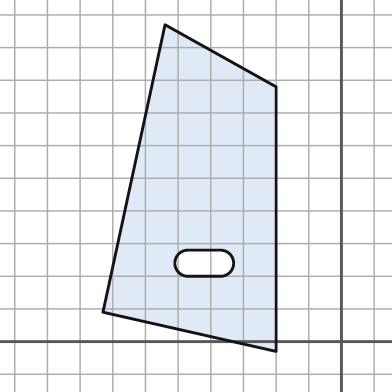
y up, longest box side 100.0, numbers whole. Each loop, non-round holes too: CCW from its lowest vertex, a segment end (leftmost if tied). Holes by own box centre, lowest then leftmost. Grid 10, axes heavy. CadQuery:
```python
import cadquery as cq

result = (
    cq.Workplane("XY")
    .moveTo(-20.0, -3.0)
    .lineTo(-20.0, 78.0)
    .lineTo(-54.0, 97.0)
    .lineTo(-73.0, 9.0)
    .close()
    .moveTo(-47.0, 20.0)
    .lineTo(-37.0, 20.0)
    .threePointArc((-33.0, 24.0), (-37.0, 28.0))
    .lineTo(-47.0, 28.0)
    .threePointArc((-51.0, 24.0), (-47.0, 20.0))
    .close()
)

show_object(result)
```